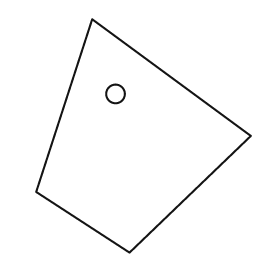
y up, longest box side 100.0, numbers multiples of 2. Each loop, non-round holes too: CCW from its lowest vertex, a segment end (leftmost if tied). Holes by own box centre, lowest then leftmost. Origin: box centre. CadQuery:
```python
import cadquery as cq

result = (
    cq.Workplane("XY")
    .moveTo(-6.0, -50.0)
    .lineTo(46.0, 0.0)
    .lineTo(-22.0, 50.0)
    .lineTo(-46.0, -24.0)
    .close()
    .moveTo(-12.0, 18.0)
    .circle(4.0)
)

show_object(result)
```